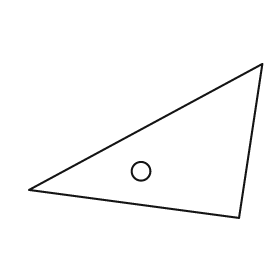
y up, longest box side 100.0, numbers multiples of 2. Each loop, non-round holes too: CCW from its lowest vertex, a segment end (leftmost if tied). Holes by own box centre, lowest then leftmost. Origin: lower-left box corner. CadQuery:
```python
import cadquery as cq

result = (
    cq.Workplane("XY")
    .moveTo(90.0, 0.0)
    .lineTo(100.0, 66.0)
    .lineTo(0.0, 12.0)
    .close()
    .moveTo(48.0, 20.0)
    .circle(4.0)
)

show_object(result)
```